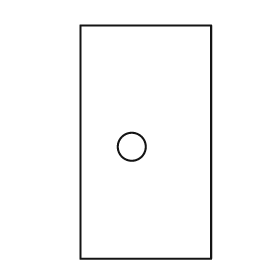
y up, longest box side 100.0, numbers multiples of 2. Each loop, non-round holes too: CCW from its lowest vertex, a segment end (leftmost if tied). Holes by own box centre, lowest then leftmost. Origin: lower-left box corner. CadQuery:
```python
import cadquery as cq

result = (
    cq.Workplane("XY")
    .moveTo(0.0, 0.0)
    .lineTo(56.0, 0.0)
    .lineTo(56.0, 100.0)
    .lineTo(0.0, 100.0)
    .close()
    .moveTo(22.0, 48.0)
    .circle(6.0)
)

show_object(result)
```